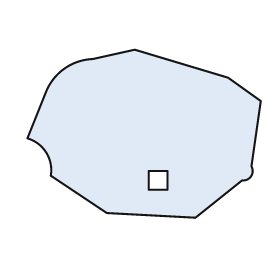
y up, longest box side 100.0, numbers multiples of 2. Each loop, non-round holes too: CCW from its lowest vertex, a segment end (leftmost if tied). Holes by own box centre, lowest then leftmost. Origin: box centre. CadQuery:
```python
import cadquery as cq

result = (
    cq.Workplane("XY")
    .moveTo(22.0, -36.0)
    .lineTo(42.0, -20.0)
    .threePointArc((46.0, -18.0), (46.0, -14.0))
    .lineTo(50.0, 14.0)
    .lineTo(36.0, 24.0)
    .lineTo(-4.0, 36.0)
    .lineTo(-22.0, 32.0)
    .threePointArc((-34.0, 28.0), (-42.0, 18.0))
    .lineTo(-50.0, -2.0)
    .threePointArc((-42.0, -8.0), (-40.0, -18.0))
    .lineTo(-16.0, -34.0)
    .close()
    .moveTo(2.0, -24.0)
    .lineTo(10.0, -24.0)
    .lineTo(10.0, -16.0)
    .lineTo(2.0, -16.0)
    .close()
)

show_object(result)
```